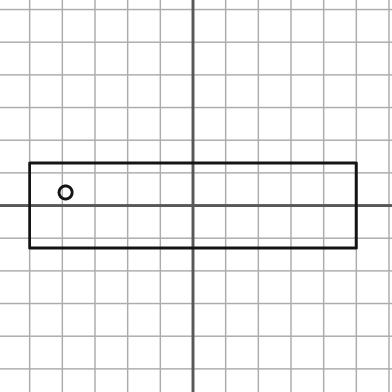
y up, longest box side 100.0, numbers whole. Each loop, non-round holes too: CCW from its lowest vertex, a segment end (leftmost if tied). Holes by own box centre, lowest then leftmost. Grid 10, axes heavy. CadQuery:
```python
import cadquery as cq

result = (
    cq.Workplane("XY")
    .moveTo(-50.0, -13.0)
    .lineTo(50.0, -13.0)
    .lineTo(50.0, 13.0)
    .lineTo(-50.0, 13.0)
    .close()
    .moveTo(-39.0, 4.0)
    .circle(2.0)
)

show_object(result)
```